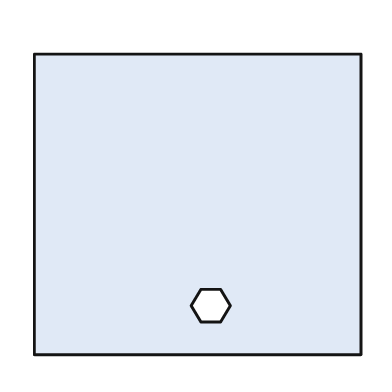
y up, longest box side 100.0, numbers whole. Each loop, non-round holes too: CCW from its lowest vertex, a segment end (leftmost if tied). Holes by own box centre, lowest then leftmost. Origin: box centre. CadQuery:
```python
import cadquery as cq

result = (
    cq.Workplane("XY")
    .moveTo(-50.0, -46.0)
    .lineTo(50.0, -46.0)
    .lineTo(50.0, 46.0)
    .lineTo(-50.0, 46.0)
    .close()
    .moveTo(1.0, -36.0)
    .lineTo(7.0, -36.0)
    .lineTo(10.0, -31.0)
    .lineTo(7.0, -26.0)
    .lineTo(1.0, -26.0)
    .lineTo(-2.0, -31.0)
    .close()
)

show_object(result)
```